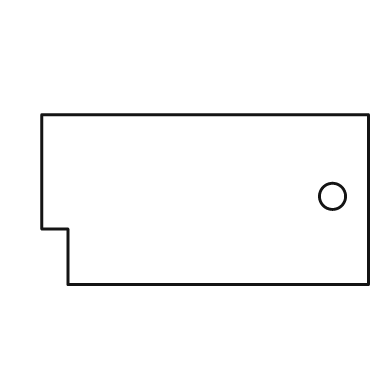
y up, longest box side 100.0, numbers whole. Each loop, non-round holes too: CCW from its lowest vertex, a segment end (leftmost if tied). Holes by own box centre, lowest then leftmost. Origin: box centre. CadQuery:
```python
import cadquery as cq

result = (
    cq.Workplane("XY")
    .moveTo(-42.0, -26.0)
    .lineTo(50.0, -26.0)
    .lineTo(50.0, 26.0)
    .lineTo(-50.0, 26.0)
    .lineTo(-50.0, -9.0)
    .lineTo(-42.0, -9.0)
    .close()
    .moveTo(39.0, 1.0)
    .circle(4.0)
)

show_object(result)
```